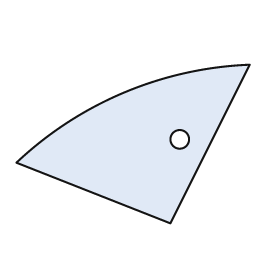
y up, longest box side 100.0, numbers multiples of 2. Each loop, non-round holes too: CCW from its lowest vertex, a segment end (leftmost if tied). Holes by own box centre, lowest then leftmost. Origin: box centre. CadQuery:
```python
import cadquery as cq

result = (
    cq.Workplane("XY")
    .moveTo(16.0, -34.0)
    .lineTo(50.0, 34.0)
    .threePointArc((-4.0, 22.0), (-50.0, -8.0))
    .close()
    .moveTo(20.0, 2.0)
    .circle(4.0)
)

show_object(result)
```